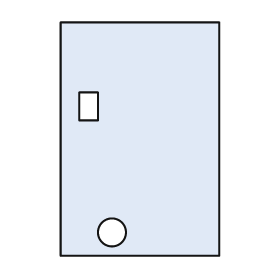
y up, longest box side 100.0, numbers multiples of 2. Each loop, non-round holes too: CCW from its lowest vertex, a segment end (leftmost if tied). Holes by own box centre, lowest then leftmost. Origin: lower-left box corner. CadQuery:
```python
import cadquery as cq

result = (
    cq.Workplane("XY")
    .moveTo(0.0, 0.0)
    .lineTo(68.0, 0.0)
    .lineTo(68.0, 100.0)
    .lineTo(0.0, 100.0)
    .close()
    .moveTo(22.0, 10.0)
    .circle(6.0)
    .moveTo(8.0, 58.0)
    .lineTo(16.0, 58.0)
    .lineTo(16.0, 70.0)
    .lineTo(8.0, 70.0)
    .close()
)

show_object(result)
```